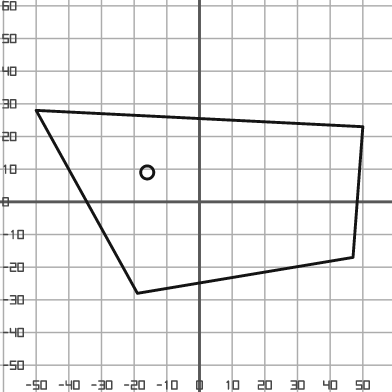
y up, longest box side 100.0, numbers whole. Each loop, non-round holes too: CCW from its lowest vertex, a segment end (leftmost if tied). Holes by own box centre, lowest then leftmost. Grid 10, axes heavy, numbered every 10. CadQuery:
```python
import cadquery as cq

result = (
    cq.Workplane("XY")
    .moveTo(-19.0, -28.0)
    .lineTo(47.0, -17.0)
    .lineTo(50.0, 23.0)
    .lineTo(-50.0, 28.0)
    .close()
    .moveTo(-16.0, 9.0)
    .circle(2.0)
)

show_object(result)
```